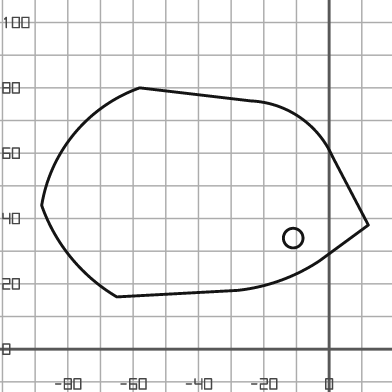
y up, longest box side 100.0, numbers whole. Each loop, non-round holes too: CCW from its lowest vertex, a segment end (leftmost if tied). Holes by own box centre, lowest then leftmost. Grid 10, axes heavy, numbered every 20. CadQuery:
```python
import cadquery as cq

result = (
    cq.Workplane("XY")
    .moveTo(-65.0, 16.0)
    .lineTo(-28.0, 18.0)
    .threePointArc((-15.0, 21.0), (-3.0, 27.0))
    .lineTo(12.0, 38.0)
    .lineTo(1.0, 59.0)
    .threePointArc((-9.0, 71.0), (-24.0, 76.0))
    .lineTo(-58.0, 80.0)
    .threePointArc((-78.0, 66.0), (-88.0, 44.0))
    .threePointArc((-79.0, 28.0), (-65.0, 16.0))
    .close()
    .moveTo(-11.0, 34.0)
    .circle(3.0)
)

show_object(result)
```